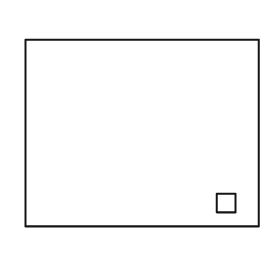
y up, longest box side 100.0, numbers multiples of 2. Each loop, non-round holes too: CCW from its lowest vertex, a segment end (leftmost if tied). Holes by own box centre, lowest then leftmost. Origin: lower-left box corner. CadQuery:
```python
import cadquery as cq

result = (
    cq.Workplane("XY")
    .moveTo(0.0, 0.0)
    .lineTo(100.0, 0.0)
    .lineTo(100.0, 80.0)
    .lineTo(0.0, 80.0)
    .close()
    .moveTo(82.0, 6.0)
    .lineTo(90.0, 6.0)
    .lineTo(90.0, 14.0)
    .lineTo(82.0, 14.0)
    .close()
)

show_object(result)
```